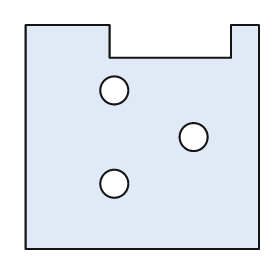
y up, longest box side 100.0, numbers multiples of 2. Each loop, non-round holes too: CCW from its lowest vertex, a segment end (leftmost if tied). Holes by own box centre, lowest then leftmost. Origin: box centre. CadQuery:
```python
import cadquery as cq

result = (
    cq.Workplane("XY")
    .moveTo(-50.0, -48.0)
    .lineTo(50.0, -48.0)
    .lineTo(50.0, 48.0)
    .lineTo(38.0, 48.0)
    .lineTo(38.0, 34.0)
    .lineTo(-14.0, 34.0)
    .lineTo(-14.0, 48.0)
    .lineTo(-50.0, 48.0)
    .close()
    .moveTo(-12.0, -20.0)
    .circle(6.0)
    .moveTo(22.0, 0.0)
    .circle(6.0)
    .moveTo(-12.0, 20.0)
    .circle(6.0)
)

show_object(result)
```